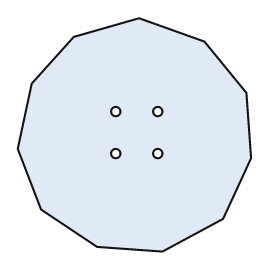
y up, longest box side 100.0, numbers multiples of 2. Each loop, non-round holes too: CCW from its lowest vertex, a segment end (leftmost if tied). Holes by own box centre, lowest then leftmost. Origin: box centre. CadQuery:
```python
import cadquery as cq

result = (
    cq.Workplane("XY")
    .moveTo(12.0, -50.0)
    .lineTo(38.0, -36.0)
    .lineTo(50.0, -10.0)
    .lineTo(48.0, 18.0)
    .lineTo(30.0, 40.0)
    .lineTo(2.0, 50.0)
    .lineTo(-26.0, 42.0)
    .lineTo(-44.0, 22.0)
    .lineTo(-50.0, -6.0)
    .lineTo(-40.0, -32.0)
    .lineTo(-16.0, -48.0)
    .close()
    .moveTo(-8.0, -8.0)
    .circle(2.0)
    .moveTo(10.0, -8.0)
    .circle(2.0)
    .moveTo(-8.0, 10.0)
    .circle(2.0)
    .moveTo(10.0, 10.0)
    .circle(2.0)
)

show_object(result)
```